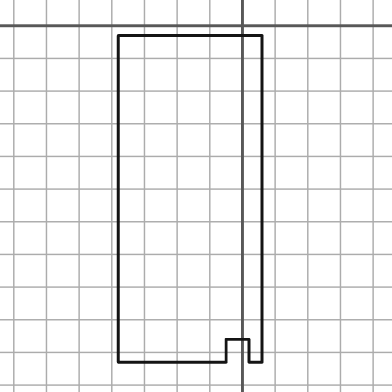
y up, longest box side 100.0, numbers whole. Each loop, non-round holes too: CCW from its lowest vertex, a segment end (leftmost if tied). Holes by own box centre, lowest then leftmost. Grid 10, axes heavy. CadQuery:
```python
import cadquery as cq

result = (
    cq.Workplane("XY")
    .moveTo(-38.0, -103.0)
    .lineTo(-5.0, -103.0)
    .lineTo(-5.0, -96.0)
    .lineTo(2.0, -96.0)
    .lineTo(2.0, -103.0)
    .lineTo(6.0, -103.0)
    .lineTo(6.0, -3.0)
    .lineTo(-38.0, -3.0)
    .close()
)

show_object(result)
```